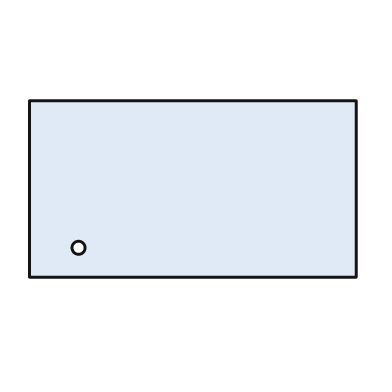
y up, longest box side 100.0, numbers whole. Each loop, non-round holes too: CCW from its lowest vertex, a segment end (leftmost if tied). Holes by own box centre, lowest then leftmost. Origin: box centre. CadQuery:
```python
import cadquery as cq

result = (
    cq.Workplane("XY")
    .moveTo(-50.0, -27.0)
    .lineTo(50.0, -27.0)
    .lineTo(50.0, 27.0)
    .lineTo(-50.0, 27.0)
    .close()
    .moveTo(-35.0, -18.0)
    .circle(2.0)
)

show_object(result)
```